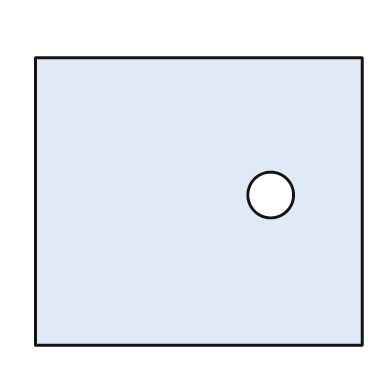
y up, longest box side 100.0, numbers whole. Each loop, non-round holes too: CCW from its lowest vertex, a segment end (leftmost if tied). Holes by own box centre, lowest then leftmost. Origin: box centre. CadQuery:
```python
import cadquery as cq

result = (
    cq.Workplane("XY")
    .moveTo(-50.0, -44.0)
    .lineTo(50.0, -44.0)
    .lineTo(50.0, 44.0)
    .lineTo(-50.0, 44.0)
    .close()
    .moveTo(22.0, 2.0)
    .circle(7.0)
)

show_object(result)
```